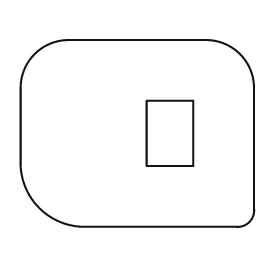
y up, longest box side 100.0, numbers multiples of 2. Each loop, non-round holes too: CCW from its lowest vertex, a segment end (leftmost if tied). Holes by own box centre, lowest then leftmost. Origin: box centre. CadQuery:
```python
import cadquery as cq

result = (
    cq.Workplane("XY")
    .moveTo(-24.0, -40.0)
    .lineTo(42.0, -40.0)
    .threePointArc((48.0, -38.0), (50.0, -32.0))
    .lineTo(50.0, 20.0)
    .threePointArc((44.0, 34.0), (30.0, 40.0))
    .lineTo(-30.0, 40.0)
    .threePointArc((-44.0, 34.0), (-50.0, 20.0))
    .lineTo(-50.0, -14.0)
    .threePointArc((-42.0, -32.0), (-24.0, -40.0))
    .close()
    .moveTo(4.0, -14.0)
    .lineTo(24.0, -14.0)
    .lineTo(24.0, 14.0)
    .lineTo(4.0, 14.0)
    .close()
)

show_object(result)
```